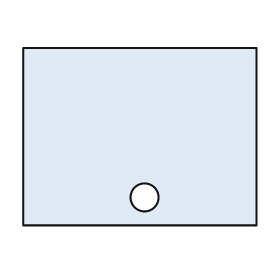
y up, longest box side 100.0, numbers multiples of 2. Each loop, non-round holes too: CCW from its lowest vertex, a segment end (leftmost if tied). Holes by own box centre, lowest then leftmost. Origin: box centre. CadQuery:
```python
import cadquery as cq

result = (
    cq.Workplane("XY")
    .moveTo(-50.0, -38.0)
    .lineTo(50.0, -38.0)
    .lineTo(50.0, 38.0)
    .lineTo(-50.0, 38.0)
    .close()
    .moveTo(2.0, -26.0)
    .circle(6.0)
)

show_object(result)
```